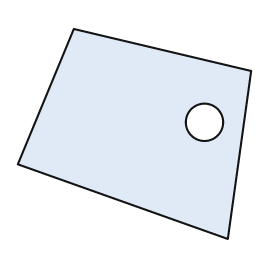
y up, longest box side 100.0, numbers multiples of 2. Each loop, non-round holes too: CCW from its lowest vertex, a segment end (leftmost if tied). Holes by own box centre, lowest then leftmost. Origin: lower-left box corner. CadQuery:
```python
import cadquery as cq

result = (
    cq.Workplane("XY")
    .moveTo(90.0, 0.0)
    .lineTo(100.0, 72.0)
    .lineTo(24.0, 90.0)
    .lineTo(0.0, 32.0)
    .close()
    .moveTo(80.0, 50.0)
    .circle(8.0)
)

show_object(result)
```